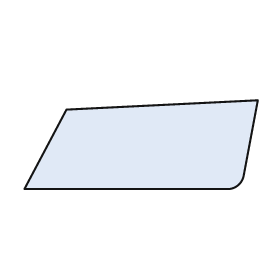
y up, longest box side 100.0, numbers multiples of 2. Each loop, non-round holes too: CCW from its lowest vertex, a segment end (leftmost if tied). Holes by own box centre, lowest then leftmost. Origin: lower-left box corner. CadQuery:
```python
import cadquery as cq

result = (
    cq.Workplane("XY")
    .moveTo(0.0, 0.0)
    .lineTo(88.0, 0.0)
    .threePointArc((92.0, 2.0), (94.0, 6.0))
    .lineTo(100.0, 38.0)
    .lineTo(18.0, 34.0)
    .close()
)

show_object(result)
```